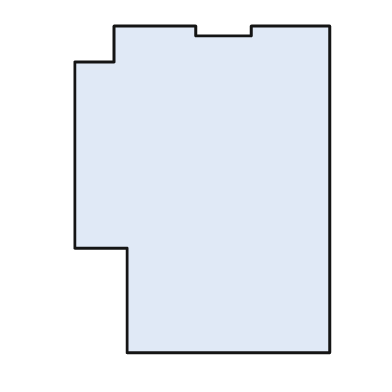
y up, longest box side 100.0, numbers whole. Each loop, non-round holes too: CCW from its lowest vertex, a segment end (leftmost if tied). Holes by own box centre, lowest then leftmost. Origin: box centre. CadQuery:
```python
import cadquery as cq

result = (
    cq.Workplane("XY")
    .moveTo(-23.0, -50.0)
    .lineTo(39.0, -50.0)
    .lineTo(39.0, 50.0)
    .lineTo(15.0, 50.0)
    .lineTo(15.0, 47.0)
    .lineTo(-2.0, 47.0)
    .lineTo(-2.0, 50.0)
    .lineTo(-27.0, 50.0)
    .lineTo(-27.0, 39.0)
    .lineTo(-39.0, 39.0)
    .lineTo(-39.0, -18.0)
    .lineTo(-23.0, -18.0)
    .close()
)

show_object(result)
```